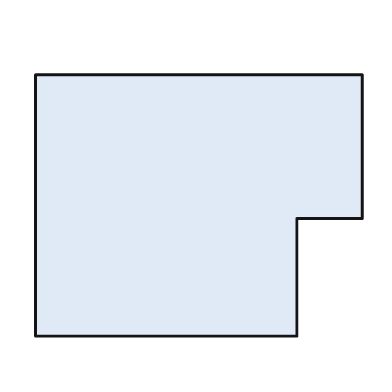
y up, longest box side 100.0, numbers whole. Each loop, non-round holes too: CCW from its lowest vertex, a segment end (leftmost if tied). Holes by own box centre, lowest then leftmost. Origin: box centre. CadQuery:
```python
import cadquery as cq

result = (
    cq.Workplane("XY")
    .moveTo(-50.0, -40.0)
    .lineTo(30.0, -40.0)
    .lineTo(30.0, -4.0)
    .lineTo(50.0, -4.0)
    .lineTo(50.0, 40.0)
    .lineTo(-50.0, 40.0)
    .close()
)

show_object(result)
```